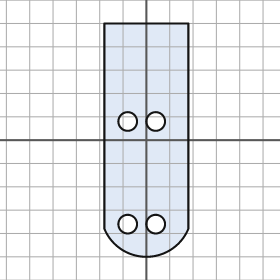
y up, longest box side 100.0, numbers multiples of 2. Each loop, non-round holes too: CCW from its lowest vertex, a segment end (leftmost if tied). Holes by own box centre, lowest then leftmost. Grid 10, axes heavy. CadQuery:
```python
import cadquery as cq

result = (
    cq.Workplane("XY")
    .moveTo(-18.0, -38.0)
    .threePointArc((0.0, -50.0), (18.0, -38.0))
    .lineTo(18.0, 50.0)
    .lineTo(-18.0, 50.0)
    .close()
    .moveTo(-8.0, -36.0)
    .circle(4.0)
    .moveTo(4.0, -36.0)
    .circle(4.0)
    .moveTo(-8.0, 8.0)
    .circle(4.0)
    .moveTo(4.0, 8.0)
    .circle(4.0)
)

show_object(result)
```